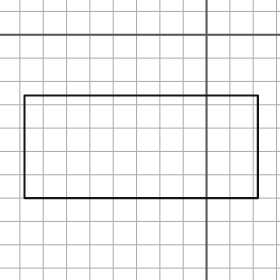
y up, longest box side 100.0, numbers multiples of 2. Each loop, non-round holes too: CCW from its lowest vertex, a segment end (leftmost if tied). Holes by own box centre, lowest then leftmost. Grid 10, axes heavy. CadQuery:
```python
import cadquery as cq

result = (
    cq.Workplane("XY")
    .moveTo(-78.0, -70.0)
    .lineTo(22.0, -70.0)
    .lineTo(22.0, -26.0)
    .lineTo(-78.0, -26.0)
    .close()
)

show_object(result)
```